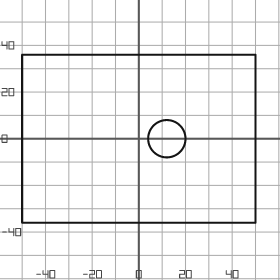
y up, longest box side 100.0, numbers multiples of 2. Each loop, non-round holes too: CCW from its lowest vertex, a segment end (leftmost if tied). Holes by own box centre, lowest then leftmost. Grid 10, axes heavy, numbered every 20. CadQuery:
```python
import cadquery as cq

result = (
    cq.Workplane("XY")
    .moveTo(-50.0, -36.0)
    .lineTo(50.0, -36.0)
    .lineTo(50.0, 36.0)
    .lineTo(-50.0, 36.0)
    .close()
    .moveTo(12.0, 0.0)
    .circle(8.0)
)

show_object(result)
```